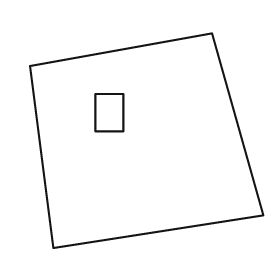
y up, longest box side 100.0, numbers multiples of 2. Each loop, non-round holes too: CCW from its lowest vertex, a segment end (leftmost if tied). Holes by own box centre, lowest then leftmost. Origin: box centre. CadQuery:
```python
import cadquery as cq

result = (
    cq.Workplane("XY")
    .moveTo(-40.0, -46.0)
    .lineTo(50.0, -32.0)
    .lineTo(28.0, 46.0)
    .lineTo(-50.0, 32.0)
    .close()
    .moveTo(-22.0, 4.0)
    .lineTo(-10.0, 4.0)
    .lineTo(-10.0, 20.0)
    .lineTo(-22.0, 20.0)
    .close()
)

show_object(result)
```